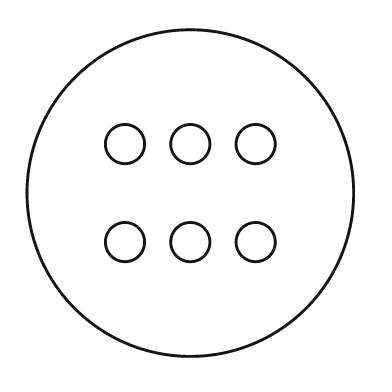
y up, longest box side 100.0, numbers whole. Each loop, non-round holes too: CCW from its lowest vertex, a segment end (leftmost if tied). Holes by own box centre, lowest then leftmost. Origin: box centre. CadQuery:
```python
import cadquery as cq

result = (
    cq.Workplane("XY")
    .moveTo(0.0, 0.0)
    .circle(50.0)
    .moveTo(-20.0, -15.0)
    .circle(6.0)
    .moveTo(0.0, -15.0)
    .circle(6.0)
    .moveTo(20.0, -15.0)
    .circle(6.0)
    .moveTo(-20.0, 15.0)
    .circle(6.0)
    .moveTo(0.0, 15.0)
    .circle(6.0)
    .moveTo(20.0, 15.0)
    .circle(6.0)
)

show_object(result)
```